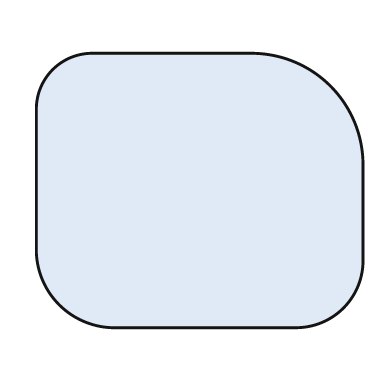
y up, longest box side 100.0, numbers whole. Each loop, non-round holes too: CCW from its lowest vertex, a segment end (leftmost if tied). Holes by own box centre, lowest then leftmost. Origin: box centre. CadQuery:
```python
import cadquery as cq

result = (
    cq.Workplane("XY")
    .moveTo(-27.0, -42.0)
    .lineTo(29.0, -42.0)
    .threePointArc((44.0, -36.0), (50.0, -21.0))
    .lineTo(50.0, 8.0)
    .threePointArc((40.0, 32.0), (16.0, 42.0))
    .lineTo(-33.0, 42.0)
    .threePointArc((-45.0, 37.0), (-50.0, 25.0))
    .lineTo(-50.0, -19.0)
    .threePointArc((-43.0, -35.0), (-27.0, -42.0))
    .close()
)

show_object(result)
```